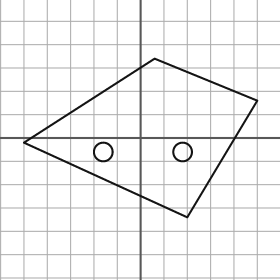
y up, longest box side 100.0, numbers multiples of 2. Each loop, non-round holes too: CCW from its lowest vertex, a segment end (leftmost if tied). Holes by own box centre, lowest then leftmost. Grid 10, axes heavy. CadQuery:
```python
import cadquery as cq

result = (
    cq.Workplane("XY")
    .moveTo(20.0, -34.0)
    .lineTo(50.0, 16.0)
    .lineTo(6.0, 34.0)
    .lineTo(-50.0, -2.0)
    .close()
    .moveTo(-16.0, -6.0)
    .circle(4.0)
    .moveTo(18.0, -6.0)
    .circle(4.0)
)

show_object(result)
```